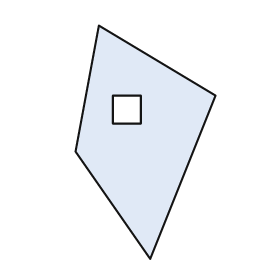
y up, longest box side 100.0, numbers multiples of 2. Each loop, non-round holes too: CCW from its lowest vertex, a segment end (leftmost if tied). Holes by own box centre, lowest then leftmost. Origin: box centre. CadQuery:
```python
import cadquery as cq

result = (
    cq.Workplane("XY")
    .moveTo(2.0, -50.0)
    .lineTo(30.0, 20.0)
    .lineTo(-20.0, 50.0)
    .lineTo(-30.0, -4.0)
    .close()
    .moveTo(-14.0, 8.0)
    .lineTo(-2.0, 8.0)
    .lineTo(-2.0, 20.0)
    .lineTo(-14.0, 20.0)
    .close()
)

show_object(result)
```